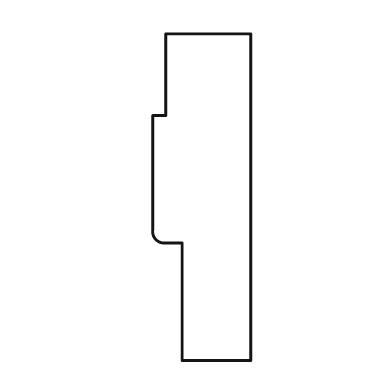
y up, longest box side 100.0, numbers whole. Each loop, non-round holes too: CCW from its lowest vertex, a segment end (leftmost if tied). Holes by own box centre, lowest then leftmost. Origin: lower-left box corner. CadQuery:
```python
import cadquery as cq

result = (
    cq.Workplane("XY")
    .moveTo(9.0, 0.0)
    .lineTo(30.0, 0.0)
    .lineTo(30.0, 100.0)
    .lineTo(4.0, 100.0)
    .lineTo(4.0, 75.0)
    .lineTo(0.0, 75.0)
    .lineTo(0.0, 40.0)
    .threePointArc((1.0, 37.0), (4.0, 36.0))
    .lineTo(9.0, 36.0)
    .close()
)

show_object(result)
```